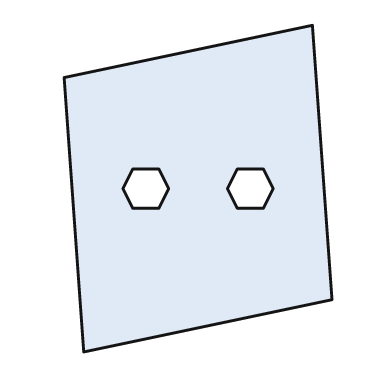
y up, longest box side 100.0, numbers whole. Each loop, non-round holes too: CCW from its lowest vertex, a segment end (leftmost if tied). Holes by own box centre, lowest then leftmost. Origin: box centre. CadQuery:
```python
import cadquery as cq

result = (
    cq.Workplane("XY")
    .moveTo(-35.0, -50.0)
    .lineTo(41.0, -34.0)
    .lineTo(35.0, 50.0)
    .lineTo(-41.0, 34.0)
    .close()
    .moveTo(-20.0, -6.0)
    .lineTo(-12.0, -6.0)
    .lineTo(-9.0, 0.0)
    .lineTo(-12.0, 6.0)
    .lineTo(-20.0, 6.0)
    .lineTo(-23.0, 0.0)
    .close()
    .moveTo(12.0, -6.0)
    .lineTo(20.0, -6.0)
    .lineTo(23.0, 0.0)
    .lineTo(20.0, 6.0)
    .lineTo(12.0, 6.0)
    .lineTo(9.0, 0.0)
    .close()
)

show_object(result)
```